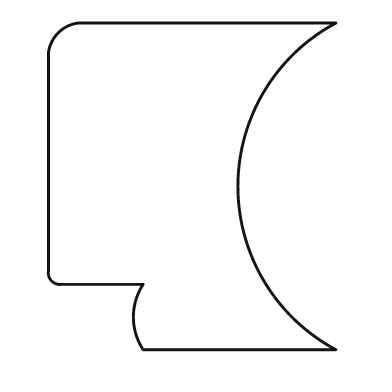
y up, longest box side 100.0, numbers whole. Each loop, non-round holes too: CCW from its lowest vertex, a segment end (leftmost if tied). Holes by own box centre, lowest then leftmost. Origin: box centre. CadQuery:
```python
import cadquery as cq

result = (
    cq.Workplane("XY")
    .moveTo(-15.0, -50.0)
    .lineTo(44.0, -50.0)
    .threePointArc((14.0, 0.0), (44.0, 50.0))
    .lineTo(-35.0, 50.0)
    .threePointArc((-41.0, 47.0), (-44.0, 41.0))
    .lineTo(-44.0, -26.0)
    .threePointArc((-43.0, -29.0), (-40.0, -30.0))
    .lineTo(-15.0, -30.0)
    .threePointArc((-18.0, -40.0), (-15.0, -50.0))
    .close()
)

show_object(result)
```